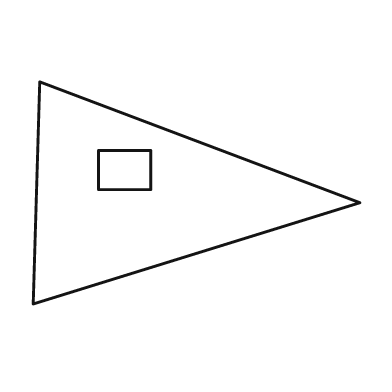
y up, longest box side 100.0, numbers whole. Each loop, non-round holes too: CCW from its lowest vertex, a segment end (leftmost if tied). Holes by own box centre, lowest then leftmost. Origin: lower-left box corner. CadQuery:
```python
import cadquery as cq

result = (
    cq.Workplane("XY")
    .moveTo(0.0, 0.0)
    .lineTo(100.0, 31.0)
    .lineTo(2.0, 68.0)
    .close()
    .moveTo(20.0, 35.0)
    .lineTo(36.0, 35.0)
    .lineTo(36.0, 47.0)
    .lineTo(20.0, 47.0)
    .close()
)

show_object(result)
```